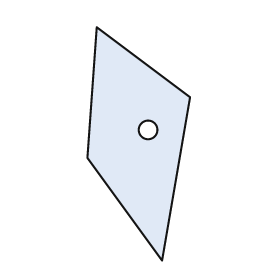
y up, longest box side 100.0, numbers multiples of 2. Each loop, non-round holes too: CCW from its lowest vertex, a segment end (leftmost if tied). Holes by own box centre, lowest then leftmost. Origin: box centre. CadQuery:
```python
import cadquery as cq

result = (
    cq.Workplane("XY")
    .moveTo(10.0, -50.0)
    .lineTo(22.0, 20.0)
    .lineTo(-18.0, 50.0)
    .lineTo(-22.0, -6.0)
    .close()
    .moveTo(4.0, 6.0)
    .circle(4.0)
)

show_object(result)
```